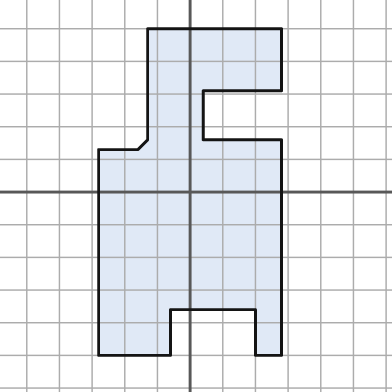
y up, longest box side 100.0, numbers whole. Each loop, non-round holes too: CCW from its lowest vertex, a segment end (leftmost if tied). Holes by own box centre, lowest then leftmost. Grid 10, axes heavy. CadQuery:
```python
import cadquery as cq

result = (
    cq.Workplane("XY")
    .moveTo(-28.0, -50.0)
    .lineTo(-6.0, -50.0)
    .lineTo(-6.0, -36.0)
    .lineTo(20.0, -36.0)
    .lineTo(20.0, -50.0)
    .lineTo(28.0, -50.0)
    .lineTo(28.0, 16.0)
    .lineTo(4.0, 16.0)
    .lineTo(4.0, 31.0)
    .lineTo(28.0, 31.0)
    .lineTo(28.0, 50.0)
    .lineTo(-13.0, 50.0)
    .lineTo(-13.0, 16.0)
    .lineTo(-16.0, 13.0)
    .lineTo(-28.0, 13.0)
    .close()
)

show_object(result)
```